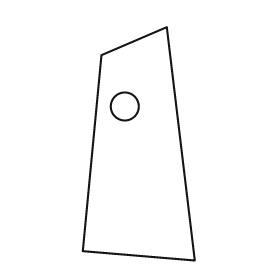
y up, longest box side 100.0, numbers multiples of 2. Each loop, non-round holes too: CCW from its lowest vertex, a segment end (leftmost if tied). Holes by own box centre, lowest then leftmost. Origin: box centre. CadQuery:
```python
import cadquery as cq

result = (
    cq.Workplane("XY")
    .moveTo(24.0, -50.0)
    .lineTo(12.0, 50.0)
    .lineTo(-16.0, 38.0)
    .lineTo(-24.0, -46.0)
    .close()
    .moveTo(-6.0, 16.0)
    .circle(6.0)
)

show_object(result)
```